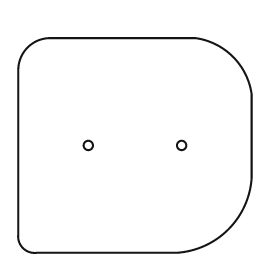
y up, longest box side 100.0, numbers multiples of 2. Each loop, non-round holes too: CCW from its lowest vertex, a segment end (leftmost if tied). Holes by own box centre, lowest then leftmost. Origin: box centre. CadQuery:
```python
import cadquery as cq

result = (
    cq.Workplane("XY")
    .moveTo(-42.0, -46.0)
    .lineTo(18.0, -46.0)
    .threePointArc((40.0, -36.0), (50.0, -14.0))
    .lineTo(50.0, 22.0)
    .threePointArc((42.0, 38.0), (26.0, 46.0))
    .lineTo(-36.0, 46.0)
    .threePointArc((-46.0, 42.0), (-50.0, 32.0))
    .lineTo(-50.0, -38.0)
    .threePointArc((-48.0, -44.0), (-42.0, -46.0))
    .close()
    .moveTo(-20.0, 0.0)
    .circle(2.0)
    .moveTo(20.0, 0.0)
    .circle(2.0)
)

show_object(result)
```